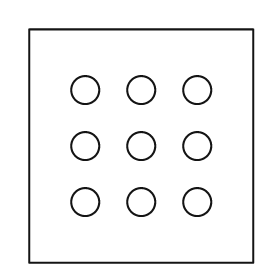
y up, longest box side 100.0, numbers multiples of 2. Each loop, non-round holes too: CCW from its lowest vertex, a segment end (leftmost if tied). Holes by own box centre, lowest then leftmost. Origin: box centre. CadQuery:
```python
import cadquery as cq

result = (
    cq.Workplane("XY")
    .moveTo(-48.0, -50.0)
    .lineTo(48.0, -50.0)
    .lineTo(48.0, 50.0)
    .lineTo(-48.0, 50.0)
    .close()
    .moveTo(-24.0, -24.0)
    .circle(6.0)
    .moveTo(0.0, -24.0)
    .circle(6.0)
    .moveTo(24.0, -24.0)
    .circle(6.0)
    .moveTo(-24.0, 0.0)
    .circle(6.0)
    .moveTo(0.0, 0.0)
    .circle(6.0)
    .moveTo(24.0, 0.0)
    .circle(6.0)
    .moveTo(-24.0, 24.0)
    .circle(6.0)
    .moveTo(0.0, 24.0)
    .circle(6.0)
    .moveTo(24.0, 24.0)
    .circle(6.0)
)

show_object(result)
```